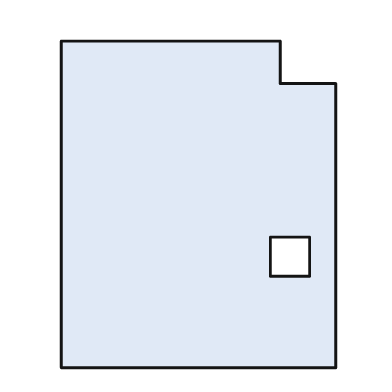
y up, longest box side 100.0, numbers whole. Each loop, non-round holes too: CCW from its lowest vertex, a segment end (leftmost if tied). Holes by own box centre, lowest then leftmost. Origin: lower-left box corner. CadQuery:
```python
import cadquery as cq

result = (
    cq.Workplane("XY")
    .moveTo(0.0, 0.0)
    .lineTo(84.0, 0.0)
    .lineTo(84.0, 87.0)
    .lineTo(67.0, 87.0)
    .lineTo(67.0, 100.0)
    .lineTo(0.0, 100.0)
    .close()
    .moveTo(64.0, 28.0)
    .lineTo(76.0, 28.0)
    .lineTo(76.0, 40.0)
    .lineTo(64.0, 40.0)
    .close()
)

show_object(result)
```